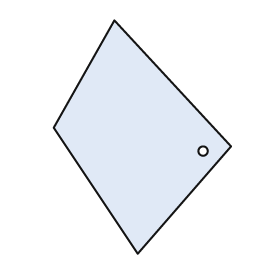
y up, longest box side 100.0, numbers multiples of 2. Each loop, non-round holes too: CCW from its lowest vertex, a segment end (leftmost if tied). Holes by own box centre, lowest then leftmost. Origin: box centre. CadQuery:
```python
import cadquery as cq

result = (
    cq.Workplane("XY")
    .moveTo(-2.0, -50.0)
    .lineTo(38.0, -4.0)
    .lineTo(-12.0, 50.0)
    .lineTo(-38.0, 4.0)
    .close()
    .moveTo(26.0, -6.0)
    .circle(2.0)
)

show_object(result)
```